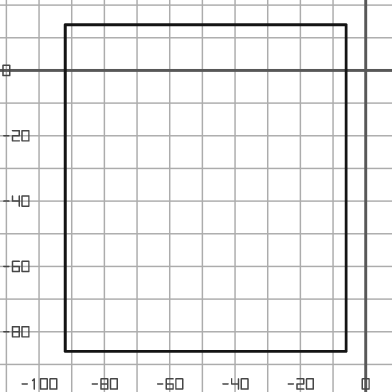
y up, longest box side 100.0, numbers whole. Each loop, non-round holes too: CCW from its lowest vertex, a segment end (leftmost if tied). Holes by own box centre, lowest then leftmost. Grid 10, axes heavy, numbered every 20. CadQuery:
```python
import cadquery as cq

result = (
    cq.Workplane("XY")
    .moveTo(-92.0, -86.0)
    .lineTo(-6.0, -86.0)
    .lineTo(-6.0, 14.0)
    .lineTo(-92.0, 14.0)
    .close()
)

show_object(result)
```